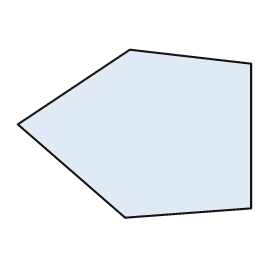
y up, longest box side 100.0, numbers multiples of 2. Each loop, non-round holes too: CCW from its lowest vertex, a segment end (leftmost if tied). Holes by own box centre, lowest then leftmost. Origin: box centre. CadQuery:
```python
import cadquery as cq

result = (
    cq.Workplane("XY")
    .moveTo(-4.0, -36.0)
    .lineTo(50.0, -32.0)
    .lineTo(50.0, 30.0)
    .lineTo(-2.0, 36.0)
    .lineTo(-50.0, 4.0)
    .close()
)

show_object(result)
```